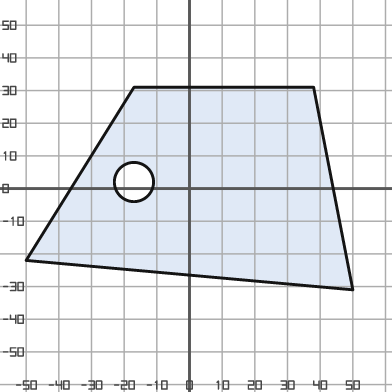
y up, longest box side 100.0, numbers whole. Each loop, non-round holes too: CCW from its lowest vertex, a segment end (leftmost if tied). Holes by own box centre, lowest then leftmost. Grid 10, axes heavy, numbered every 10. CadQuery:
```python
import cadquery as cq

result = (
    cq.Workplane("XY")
    .moveTo(50.0, -31.0)
    .lineTo(38.0, 31.0)
    .lineTo(-17.0, 31.0)
    .lineTo(-50.0, -22.0)
    .close()
    .moveTo(-17.0, 2.0)
    .circle(6.0)
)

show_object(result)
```